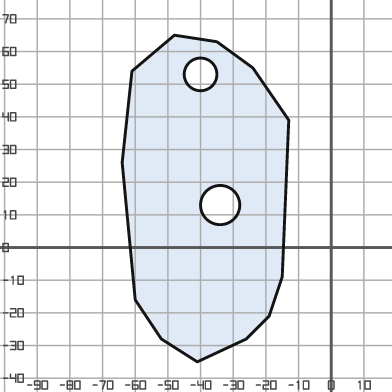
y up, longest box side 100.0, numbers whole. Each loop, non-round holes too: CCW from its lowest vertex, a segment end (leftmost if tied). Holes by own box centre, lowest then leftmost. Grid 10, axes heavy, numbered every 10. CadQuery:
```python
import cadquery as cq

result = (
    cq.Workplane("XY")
    .moveTo(-41.0, -35.0)
    .lineTo(-26.0, -28.0)
    .lineTo(-19.0, -21.0)
    .lineTo(-15.0, -9.0)
    .lineTo(-13.0, 39.0)
    .lineTo(-24.0, 55.0)
    .lineTo(-35.0, 63.0)
    .lineTo(-48.0, 65.0)
    .lineTo(-61.0, 54.0)
    .lineTo(-64.0, 26.0)
    .lineTo(-60.0, -16.0)
    .lineTo(-52.0, -28.0)
    .close()
    .moveTo(-34.0, 13.0)
    .circle(6.0)
    .moveTo(-40.0, 53.0)
    .circle(5.0)
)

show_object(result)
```